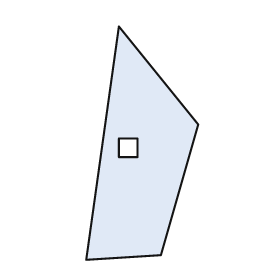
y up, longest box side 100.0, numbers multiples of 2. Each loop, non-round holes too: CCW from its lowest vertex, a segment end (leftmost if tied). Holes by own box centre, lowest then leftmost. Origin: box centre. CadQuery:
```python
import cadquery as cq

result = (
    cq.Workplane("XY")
    .moveTo(-24.0, -50.0)
    .lineTo(8.0, -48.0)
    .lineTo(24.0, 8.0)
    .lineTo(-10.0, 50.0)
    .close()
    .moveTo(-10.0, -6.0)
    .lineTo(-2.0, -6.0)
    .lineTo(-2.0, 2.0)
    .lineTo(-10.0, 2.0)
    .close()
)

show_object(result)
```